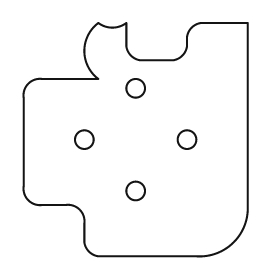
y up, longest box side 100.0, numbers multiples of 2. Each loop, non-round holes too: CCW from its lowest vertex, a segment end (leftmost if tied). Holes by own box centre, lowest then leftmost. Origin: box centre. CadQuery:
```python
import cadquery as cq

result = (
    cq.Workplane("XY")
    .moveTo(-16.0, -50.0)
    .lineTo(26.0, -50.0)
    .threePointArc((42.0, -44.0), (48.0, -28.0))
    .lineTo(48.0, 50.0)
    .lineTo(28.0, 50.0)
    .threePointArc((24.0, 48.0), (22.0, 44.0))
    .lineTo(22.0, 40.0)
    .threePointArc((20.0, 36.0), (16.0, 34.0))
    .lineTo(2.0, 34.0)
    .threePointArc((-2.0, 36.0), (-4.0, 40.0))
    .lineTo(-4.0, 50.0)
    .threePointArc((-10.0, 48.0), (-16.0, 50.0))
    .threePointArc((-22.0, 38.0), (-16.0, 26.0))
    .lineTo(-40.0, 26.0)
    .threePointArc((-46.0, 24.0), (-48.0, 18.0))
    .lineTo(-48.0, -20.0)
    .threePointArc((-46.0, -26.0), (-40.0, -28.0))
    .lineTo(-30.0, -28.0)
    .threePointArc((-24.0, -30.0), (-22.0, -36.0))
    .lineTo(-22.0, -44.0)
    .threePointArc((-20.0, -48.0), (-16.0, -50.0))
    .close()
    .moveTo(0.0, -22.0)
    .circle(4.0)
    .moveTo(-22.0, 0.0)
    .circle(4.0)
    .moveTo(22.0, 0.0)
    .circle(4.0)
    .moveTo(0.0, 22.0)
    .circle(4.0)
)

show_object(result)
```